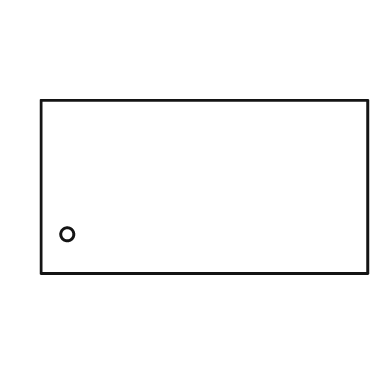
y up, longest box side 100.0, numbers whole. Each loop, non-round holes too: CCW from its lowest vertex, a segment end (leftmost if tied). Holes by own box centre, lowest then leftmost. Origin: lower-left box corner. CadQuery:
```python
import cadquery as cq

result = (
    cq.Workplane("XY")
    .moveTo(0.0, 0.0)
    .lineTo(100.0, 0.0)
    .lineTo(100.0, 53.0)
    .lineTo(0.0, 53.0)
    .close()
    .moveTo(8.0, 12.0)
    .circle(2.0)
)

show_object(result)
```